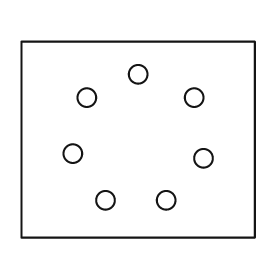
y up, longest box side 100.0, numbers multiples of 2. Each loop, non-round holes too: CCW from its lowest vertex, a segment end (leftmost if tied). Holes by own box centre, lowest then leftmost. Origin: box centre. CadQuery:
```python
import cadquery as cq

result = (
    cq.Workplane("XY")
    .moveTo(-50.0, -42.0)
    .lineTo(50.0, -42.0)
    .lineTo(50.0, 42.0)
    .lineTo(-50.0, 42.0)
    .close()
    .moveTo(-14.0, -26.0)
    .circle(4.0)
    .moveTo(12.0, -26.0)
    .circle(4.0)
    .moveTo(28.0, -8.0)
    .circle(4.0)
    .moveTo(-28.0, -6.0)
    .circle(4.0)
    .moveTo(-22.0, 18.0)
    .circle(4.0)
    .moveTo(24.0, 18.0)
    .circle(4.0)
    .moveTo(0.0, 28.0)
    .circle(4.0)
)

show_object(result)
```